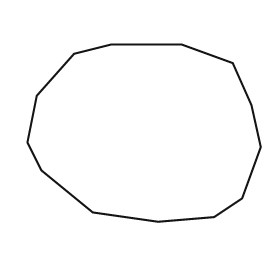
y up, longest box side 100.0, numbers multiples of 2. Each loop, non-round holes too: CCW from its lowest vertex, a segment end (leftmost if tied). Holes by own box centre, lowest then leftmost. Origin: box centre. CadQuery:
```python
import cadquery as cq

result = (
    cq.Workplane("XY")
    .moveTo(6.0, -38.0)
    .lineTo(30.0, -36.0)
    .lineTo(42.0, -28.0)
    .lineTo(50.0, -6.0)
    .lineTo(46.0, 12.0)
    .lineTo(38.0, 30.0)
    .lineTo(16.0, 38.0)
    .lineTo(-14.0, 38.0)
    .lineTo(-30.0, 34.0)
    .lineTo(-46.0, 16.0)
    .lineTo(-50.0, -4.0)
    .lineTo(-44.0, -16.0)
    .lineTo(-22.0, -34.0)
    .close()
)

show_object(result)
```